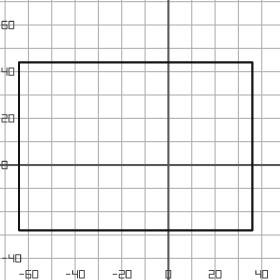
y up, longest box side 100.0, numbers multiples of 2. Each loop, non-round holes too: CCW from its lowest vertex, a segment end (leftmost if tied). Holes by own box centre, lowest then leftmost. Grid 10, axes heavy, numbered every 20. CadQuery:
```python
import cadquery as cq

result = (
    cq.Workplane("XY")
    .moveTo(-64.0, -28.0)
    .lineTo(36.0, -28.0)
    .lineTo(36.0, 44.0)
    .lineTo(-64.0, 44.0)
    .close()
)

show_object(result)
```